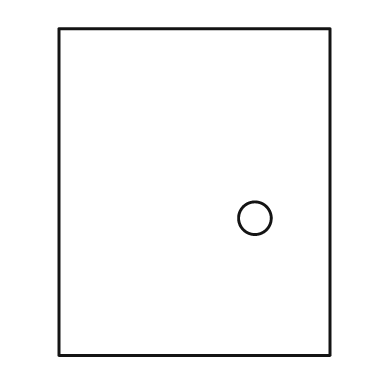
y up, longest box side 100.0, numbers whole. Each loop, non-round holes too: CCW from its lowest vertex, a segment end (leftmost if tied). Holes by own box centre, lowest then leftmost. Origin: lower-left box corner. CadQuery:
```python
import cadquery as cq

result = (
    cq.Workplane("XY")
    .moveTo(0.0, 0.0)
    .lineTo(83.0, 0.0)
    .lineTo(83.0, 100.0)
    .lineTo(0.0, 100.0)
    .close()
    .moveTo(60.0, 42.0)
    .circle(5.0)
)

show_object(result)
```